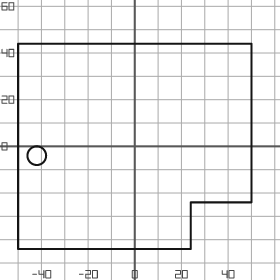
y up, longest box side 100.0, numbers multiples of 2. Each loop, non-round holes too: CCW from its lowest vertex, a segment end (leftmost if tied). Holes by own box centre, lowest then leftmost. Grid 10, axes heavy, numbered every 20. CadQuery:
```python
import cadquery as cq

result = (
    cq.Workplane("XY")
    .moveTo(-50.0, -44.0)
    .lineTo(24.0, -44.0)
    .lineTo(24.0, -24.0)
    .lineTo(50.0, -24.0)
    .lineTo(50.0, 44.0)
    .lineTo(-50.0, 44.0)
    .close()
    .moveTo(-42.0, -4.0)
    .circle(4.0)
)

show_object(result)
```